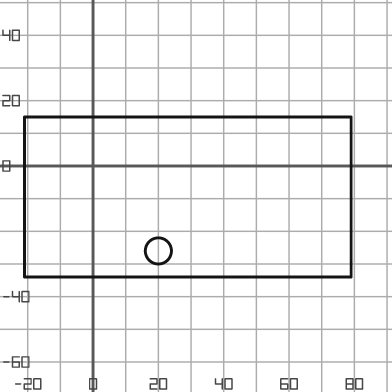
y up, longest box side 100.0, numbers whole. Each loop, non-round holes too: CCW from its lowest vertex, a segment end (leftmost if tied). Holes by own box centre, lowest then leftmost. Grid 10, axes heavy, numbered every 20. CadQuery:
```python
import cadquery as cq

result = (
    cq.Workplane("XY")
    .moveTo(-21.0, -34.0)
    .lineTo(79.0, -34.0)
    .lineTo(79.0, 15.0)
    .lineTo(-21.0, 15.0)
    .close()
    .moveTo(20.0, -26.0)
    .circle(4.0)
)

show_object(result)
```